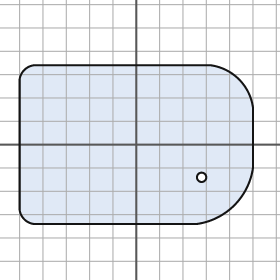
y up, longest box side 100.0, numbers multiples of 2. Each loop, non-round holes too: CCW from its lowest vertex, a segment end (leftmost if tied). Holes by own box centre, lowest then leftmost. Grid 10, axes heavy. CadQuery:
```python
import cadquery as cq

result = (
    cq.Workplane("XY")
    .moveTo(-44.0, -34.0)
    .lineTo(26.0, -34.0)
    .threePointArc((42.0, -26.0), (50.0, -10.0))
    .lineTo(50.0, 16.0)
    .threePointArc((44.0, 28.0), (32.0, 34.0))
    .lineTo(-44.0, 34.0)
    .threePointArc((-48.0, 32.0), (-50.0, 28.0))
    .lineTo(-50.0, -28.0)
    .threePointArc((-48.0, -32.0), (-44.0, -34.0))
    .close()
    .moveTo(28.0, -14.0)
    .circle(2.0)
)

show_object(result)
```